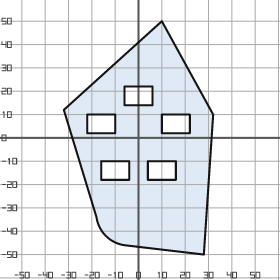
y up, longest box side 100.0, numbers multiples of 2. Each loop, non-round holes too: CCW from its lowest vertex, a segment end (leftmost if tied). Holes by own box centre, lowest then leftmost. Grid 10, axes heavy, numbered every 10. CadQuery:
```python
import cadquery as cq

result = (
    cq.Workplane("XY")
    .moveTo(28.0, -50.0)
    .lineTo(32.0, 10.0)
    .lineTo(10.0, 50.0)
    .lineTo(-32.0, 12.0)
    .lineTo(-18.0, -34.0)
    .threePointArc((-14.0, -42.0), (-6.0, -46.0))
    .close()
    .moveTo(-16.0, -18.0)
    .lineTo(-4.0, -18.0)
    .lineTo(-4.0, -10.0)
    .lineTo(-16.0, -10.0)
    .close()
    .moveTo(4.0, -18.0)
    .lineTo(16.0, -18.0)
    .lineTo(16.0, -10.0)
    .lineTo(4.0, -10.0)
    .close()
    .moveTo(-22.0, 2.0)
    .lineTo(-10.0, 2.0)
    .lineTo(-10.0, 10.0)
    .lineTo(-22.0, 10.0)
    .close()
    .moveTo(10.0, 2.0)
    .lineTo(22.0, 2.0)
    .lineTo(22.0, 10.0)
    .lineTo(10.0, 10.0)
    .close()
    .moveTo(-6.0, 14.0)
    .lineTo(6.0, 14.0)
    .lineTo(6.0, 22.0)
    .lineTo(-6.0, 22.0)
    .close()
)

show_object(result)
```